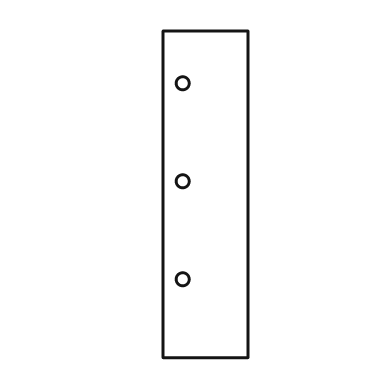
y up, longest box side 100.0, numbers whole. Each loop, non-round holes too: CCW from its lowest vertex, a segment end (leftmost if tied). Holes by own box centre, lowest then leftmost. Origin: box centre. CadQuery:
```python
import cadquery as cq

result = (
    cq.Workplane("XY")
    .moveTo(-13.0, -50.0)
    .lineTo(13.0, -50.0)
    .lineTo(13.0, 50.0)
    .lineTo(-13.0, 50.0)
    .close()
    .moveTo(-7.0, -26.0)
    .circle(2.0)
    .moveTo(-7.0, 4.0)
    .circle(2.0)
    .moveTo(-7.0, 34.0)
    .circle(2.0)
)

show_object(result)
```